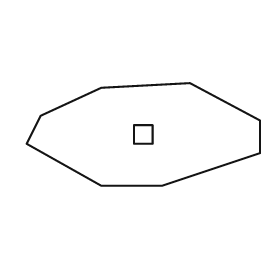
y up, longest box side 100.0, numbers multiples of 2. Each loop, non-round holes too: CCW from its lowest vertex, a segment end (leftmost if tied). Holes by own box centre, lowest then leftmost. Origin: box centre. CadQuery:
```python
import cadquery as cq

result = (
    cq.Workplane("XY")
    .moveTo(-18.0, -22.0)
    .lineTo(8.0, -22.0)
    .lineTo(50.0, -8.0)
    .lineTo(50.0, 6.0)
    .lineTo(20.0, 22.0)
    .lineTo(-18.0, 20.0)
    .lineTo(-44.0, 8.0)
    .lineTo(-50.0, -4.0)
    .close()
    .moveTo(-4.0, -4.0)
    .lineTo(4.0, -4.0)
    .lineTo(4.0, 4.0)
    .lineTo(-4.0, 4.0)
    .close()
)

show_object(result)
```